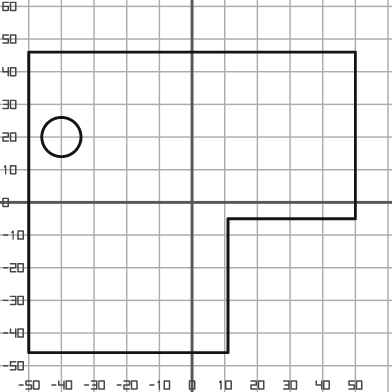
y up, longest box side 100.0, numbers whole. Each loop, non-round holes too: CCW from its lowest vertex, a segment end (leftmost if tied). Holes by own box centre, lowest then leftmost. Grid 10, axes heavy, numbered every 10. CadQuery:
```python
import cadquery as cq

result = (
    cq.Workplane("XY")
    .moveTo(-50.0, -46.0)
    .lineTo(11.0, -46.0)
    .lineTo(11.0, -5.0)
    .lineTo(50.0, -5.0)
    .lineTo(50.0, 46.0)
    .lineTo(-50.0, 46.0)
    .close()
    .moveTo(-40.0, 20.0)
    .circle(6.0)
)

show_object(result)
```